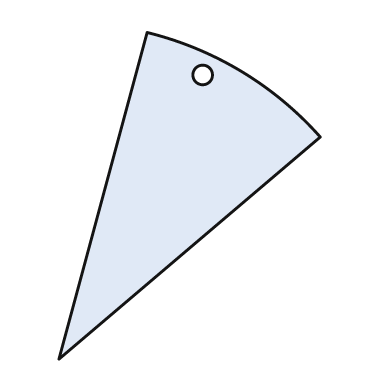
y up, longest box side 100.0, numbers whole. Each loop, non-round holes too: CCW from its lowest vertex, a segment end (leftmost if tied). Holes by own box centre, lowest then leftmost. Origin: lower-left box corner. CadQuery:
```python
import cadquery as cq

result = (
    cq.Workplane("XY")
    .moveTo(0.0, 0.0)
    .lineTo(80.0, 68.0)
    .threePointArc((56.0, 88.0), (27.0, 100.0))
    .close()
    .moveTo(44.0, 87.0)
    .circle(3.0)
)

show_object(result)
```